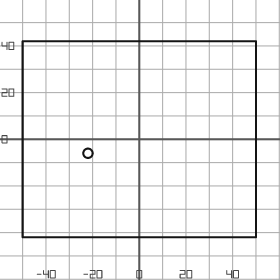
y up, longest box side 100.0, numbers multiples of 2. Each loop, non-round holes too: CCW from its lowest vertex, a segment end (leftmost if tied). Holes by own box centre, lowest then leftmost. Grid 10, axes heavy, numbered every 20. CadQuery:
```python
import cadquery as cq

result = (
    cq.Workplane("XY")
    .moveTo(-50.0, -42.0)
    .lineTo(50.0, -42.0)
    .lineTo(50.0, 42.0)
    .lineTo(-50.0, 42.0)
    .close()
    .moveTo(-22.0, -6.0)
    .circle(2.0)
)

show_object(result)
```